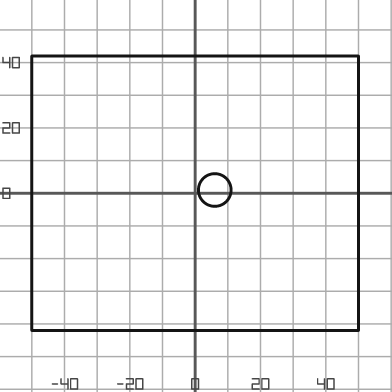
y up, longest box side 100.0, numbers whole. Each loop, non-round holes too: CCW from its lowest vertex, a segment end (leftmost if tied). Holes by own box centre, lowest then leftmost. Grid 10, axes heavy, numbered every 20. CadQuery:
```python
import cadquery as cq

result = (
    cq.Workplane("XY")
    .moveTo(-50.0, -42.0)
    .lineTo(50.0, -42.0)
    .lineTo(50.0, 42.0)
    .lineTo(-50.0, 42.0)
    .close()
    .moveTo(6.0, 1.0)
    .circle(5.0)
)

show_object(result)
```